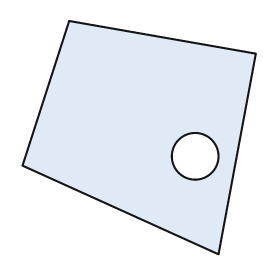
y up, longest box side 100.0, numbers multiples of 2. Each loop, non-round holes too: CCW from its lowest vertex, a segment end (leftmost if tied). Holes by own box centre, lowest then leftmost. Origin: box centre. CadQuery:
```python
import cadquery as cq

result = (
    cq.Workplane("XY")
    .moveTo(34.0, -50.0)
    .lineTo(50.0, 36.0)
    .lineTo(-30.0, 50.0)
    .lineTo(-50.0, -12.0)
    .close()
    .moveTo(24.0, -8.0)
    .circle(10.0)
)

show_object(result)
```